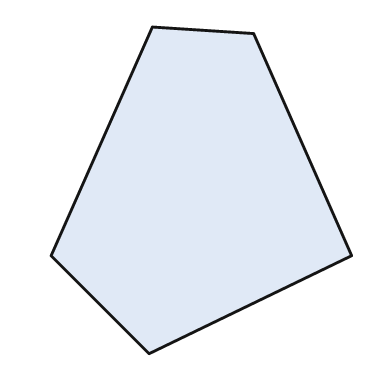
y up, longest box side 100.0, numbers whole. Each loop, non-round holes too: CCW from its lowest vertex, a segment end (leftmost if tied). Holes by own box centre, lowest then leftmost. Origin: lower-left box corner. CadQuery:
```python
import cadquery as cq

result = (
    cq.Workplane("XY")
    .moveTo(30.0, 0.0)
    .lineTo(92.0, 30.0)
    .lineTo(62.0, 98.0)
    .lineTo(31.0, 100.0)
    .lineTo(0.0, 30.0)
    .close()
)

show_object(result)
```